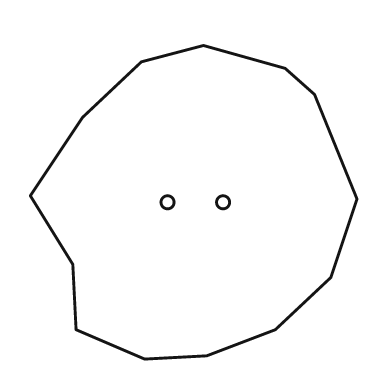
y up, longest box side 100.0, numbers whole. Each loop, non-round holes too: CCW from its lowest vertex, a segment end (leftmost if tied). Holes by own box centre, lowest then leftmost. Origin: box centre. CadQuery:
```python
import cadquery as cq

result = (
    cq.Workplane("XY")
    .moveTo(-15.0, -48.0)
    .lineTo(4.0, -47.0)
    .lineTo(25.0, -39.0)
    .lineTo(42.0, -23.0)
    .lineTo(50.0, 1.0)
    .lineTo(37.0, 33.0)
    .lineTo(28.0, 41.0)
    .lineTo(3.0, 48.0)
    .lineTo(-16.0, 43.0)
    .lineTo(-34.0, 26.0)
    .lineTo(-50.0, 2.0)
    .lineTo(-37.0, -19.0)
    .lineTo(-36.0, -39.0)
    .close()
    .moveTo(-8.0, 0.0)
    .circle(2.0)
    .moveTo(9.0, 0.0)
    .circle(2.0)
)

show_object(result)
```